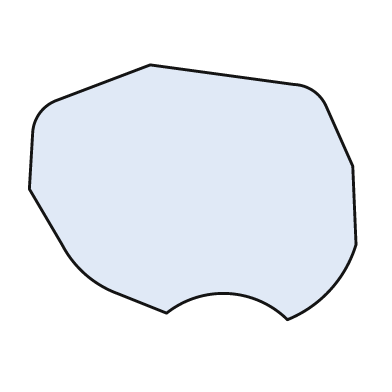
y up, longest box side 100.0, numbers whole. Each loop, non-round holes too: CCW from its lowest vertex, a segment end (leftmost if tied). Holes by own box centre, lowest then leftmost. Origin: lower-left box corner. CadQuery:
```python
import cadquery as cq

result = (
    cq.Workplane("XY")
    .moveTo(79.0, 0.0)
    .threePointArc((92.0, 9.0), (100.0, 23.0))
    .lineTo(99.0, 47.0)
    .lineTo(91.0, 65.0)
    .threePointArc((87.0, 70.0), (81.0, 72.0))
    .lineTo(37.0, 78.0)
    .lineTo(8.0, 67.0)
    .threePointArc((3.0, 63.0), (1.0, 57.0))
    .lineTo(0.0, 40.0)
    .lineTo(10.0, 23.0)
    .threePointArc((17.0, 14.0), (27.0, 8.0))
    .lineTo(42.0, 2.0)
    .threePointArc((61.0, 8.0), (79.0, 0.0))
    .close()
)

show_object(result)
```